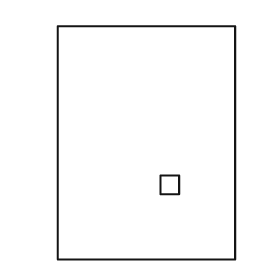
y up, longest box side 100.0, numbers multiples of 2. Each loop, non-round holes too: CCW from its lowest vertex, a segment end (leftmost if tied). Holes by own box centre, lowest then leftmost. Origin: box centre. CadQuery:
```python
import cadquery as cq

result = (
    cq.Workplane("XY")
    .moveTo(-38.0, -50.0)
    .lineTo(38.0, -50.0)
    .lineTo(38.0, 50.0)
    .lineTo(-38.0, 50.0)
    .close()
    .moveTo(6.0, -22.0)
    .lineTo(14.0, -22.0)
    .lineTo(14.0, -14.0)
    .lineTo(6.0, -14.0)
    .close()
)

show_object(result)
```